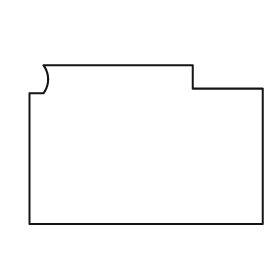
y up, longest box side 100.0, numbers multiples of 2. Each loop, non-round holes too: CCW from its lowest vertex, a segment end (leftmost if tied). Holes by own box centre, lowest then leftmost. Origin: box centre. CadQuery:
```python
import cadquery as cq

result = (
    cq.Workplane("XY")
    .moveTo(-50.0, -34.0)
    .lineTo(50.0, -34.0)
    .lineTo(50.0, 24.0)
    .lineTo(20.0, 24.0)
    .lineTo(20.0, 34.0)
    .lineTo(-44.0, 34.0)
    .threePointArc((-42.0, 28.0), (-44.0, 22.0))
    .lineTo(-50.0, 22.0)
    .close()
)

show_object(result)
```